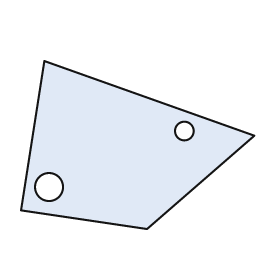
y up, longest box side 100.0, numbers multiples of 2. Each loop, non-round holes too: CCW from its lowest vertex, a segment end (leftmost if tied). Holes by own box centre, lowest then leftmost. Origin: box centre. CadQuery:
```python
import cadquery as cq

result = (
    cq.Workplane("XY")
    .moveTo(4.0, -36.0)
    .lineTo(50.0, 4.0)
    .lineTo(-40.0, 36.0)
    .lineTo(-50.0, -28.0)
    .close()
    .moveTo(-38.0, -18.0)
    .circle(6.0)
    .moveTo(20.0, 6.0)
    .circle(4.0)
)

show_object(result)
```